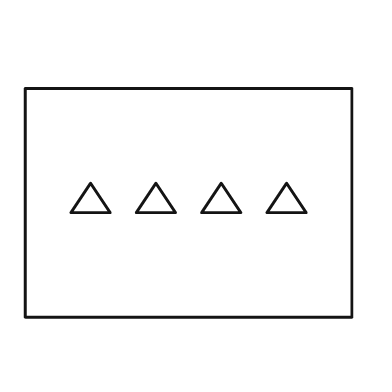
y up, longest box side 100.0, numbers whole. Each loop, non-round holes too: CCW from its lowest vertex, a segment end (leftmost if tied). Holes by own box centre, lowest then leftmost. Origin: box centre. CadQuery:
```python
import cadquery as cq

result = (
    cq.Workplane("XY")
    .moveTo(-50.0, -35.0)
    .lineTo(50.0, -35.0)
    .lineTo(50.0, 35.0)
    .lineTo(-50.0, 35.0)
    .close()
    .moveTo(-36.0, -3.0)
    .lineTo(-24.0, -3.0)
    .lineTo(-30.0, 6.0)
    .close()
    .moveTo(-16.0, -3.0)
    .lineTo(-4.0, -3.0)
    .lineTo(-10.0, 6.0)
    .close()
    .moveTo(4.0, -3.0)
    .lineTo(16.0, -3.0)
    .lineTo(10.0, 6.0)
    .close()
    .moveTo(24.0, -3.0)
    .lineTo(36.0, -3.0)
    .lineTo(30.0, 6.0)
    .close()
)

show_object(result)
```